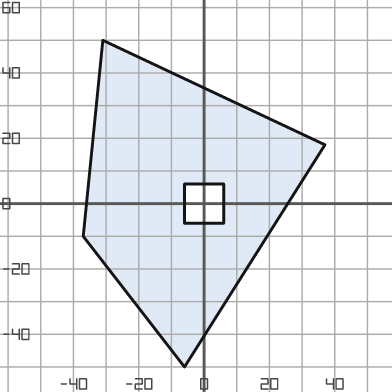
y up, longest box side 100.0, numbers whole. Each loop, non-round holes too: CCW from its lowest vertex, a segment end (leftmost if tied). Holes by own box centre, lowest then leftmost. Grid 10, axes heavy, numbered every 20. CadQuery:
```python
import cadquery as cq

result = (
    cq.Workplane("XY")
    .moveTo(-6.0, -50.0)
    .lineTo(37.0, 18.0)
    .lineTo(-31.0, 50.0)
    .lineTo(-37.0, -10.0)
    .close()
    .moveTo(-6.0, -6.0)
    .lineTo(6.0, -6.0)
    .lineTo(6.0, 6.0)
    .lineTo(-6.0, 6.0)
    .close()
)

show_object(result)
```